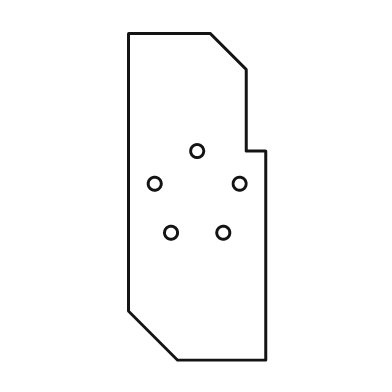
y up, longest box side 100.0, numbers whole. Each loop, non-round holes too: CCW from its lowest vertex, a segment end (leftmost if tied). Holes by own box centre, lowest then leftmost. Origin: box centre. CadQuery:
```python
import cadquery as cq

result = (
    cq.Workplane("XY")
    .moveTo(-6.0, -50.0)
    .lineTo(21.0, -50.0)
    .lineTo(21.0, 14.0)
    .lineTo(15.0, 14.0)
    .lineTo(15.0, 39.0)
    .lineTo(4.0, 50.0)
    .lineTo(-21.0, 50.0)
    .lineTo(-21.0, -35.0)
    .close()
    .moveTo(-8.0, -11.0)
    .circle(2.0)
    .moveTo(8.0, -11.0)
    .circle(2.0)
    .moveTo(-13.0, 4.0)
    .circle(2.0)
    .moveTo(13.0, 4.0)
    .circle(2.0)
    .moveTo(0.0, 14.0)
    .circle(2.0)
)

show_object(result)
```